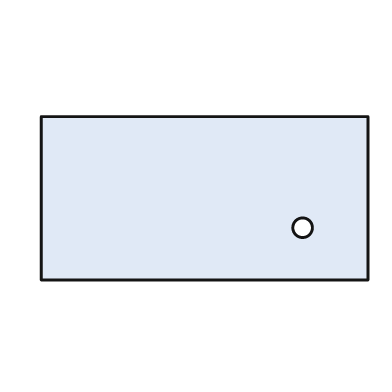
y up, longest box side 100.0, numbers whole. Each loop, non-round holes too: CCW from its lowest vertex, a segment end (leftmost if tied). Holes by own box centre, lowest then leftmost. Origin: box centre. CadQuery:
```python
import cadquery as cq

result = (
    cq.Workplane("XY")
    .moveTo(-50.0, -25.0)
    .lineTo(50.0, -25.0)
    .lineTo(50.0, 25.0)
    .lineTo(-50.0, 25.0)
    .close()
    .moveTo(30.0, -9.0)
    .circle(3.0)
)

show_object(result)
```